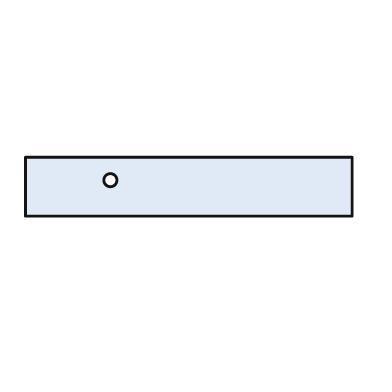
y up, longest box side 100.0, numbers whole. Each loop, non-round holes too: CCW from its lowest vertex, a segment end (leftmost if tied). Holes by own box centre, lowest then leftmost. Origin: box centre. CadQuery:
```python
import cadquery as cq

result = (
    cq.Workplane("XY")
    .moveTo(-50.0, -9.0)
    .lineTo(50.0, -9.0)
    .lineTo(50.0, 9.0)
    .lineTo(-50.0, 9.0)
    .close()
    .moveTo(-24.0, 2.0)
    .circle(2.0)
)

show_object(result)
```